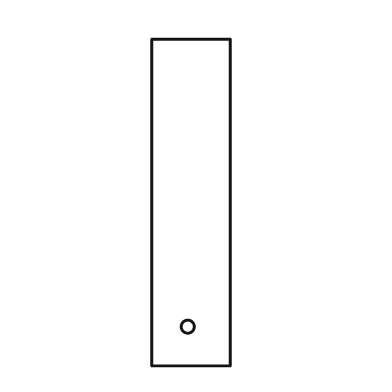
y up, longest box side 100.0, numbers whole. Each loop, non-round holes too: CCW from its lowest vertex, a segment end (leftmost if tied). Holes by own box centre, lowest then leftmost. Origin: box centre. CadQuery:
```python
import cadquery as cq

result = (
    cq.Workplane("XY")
    .moveTo(-12.0, -50.0)
    .lineTo(12.0, -50.0)
    .lineTo(12.0, 50.0)
    .lineTo(-12.0, 50.0)
    .close()
    .moveTo(-1.0, -38.0)
    .circle(2.0)
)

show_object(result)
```